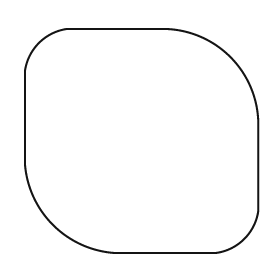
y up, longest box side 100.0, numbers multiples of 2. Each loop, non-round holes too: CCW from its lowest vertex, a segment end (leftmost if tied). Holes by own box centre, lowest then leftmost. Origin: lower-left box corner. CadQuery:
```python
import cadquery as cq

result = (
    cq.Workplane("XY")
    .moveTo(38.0, 0.0)
    .lineTo(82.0, 0.0)
    .threePointArc((94.0, 6.0), (100.0, 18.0))
    .lineTo(100.0, 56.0)
    .threePointArc((88.0, 84.0), (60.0, 96.0))
    .lineTo(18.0, 96.0)
    .threePointArc((6.0, 90.0), (0.0, 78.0))
    .lineTo(0.0, 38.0)
    .threePointArc((12.0, 12.0), (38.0, 0.0))
    .close()
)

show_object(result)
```